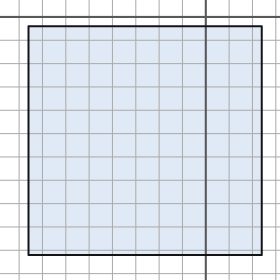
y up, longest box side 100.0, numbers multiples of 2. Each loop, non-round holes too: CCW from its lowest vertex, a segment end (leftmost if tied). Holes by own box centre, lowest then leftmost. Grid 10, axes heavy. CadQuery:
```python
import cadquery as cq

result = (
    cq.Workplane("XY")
    .moveTo(-76.0, -102.0)
    .lineTo(24.0, -102.0)
    .lineTo(24.0, -4.0)
    .lineTo(-76.0, -4.0)
    .close()
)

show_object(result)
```